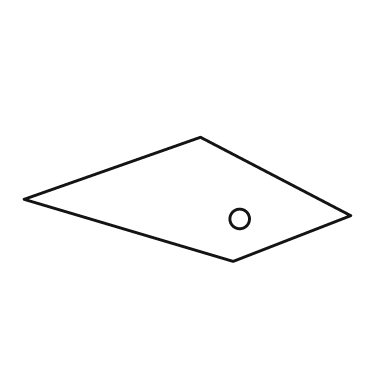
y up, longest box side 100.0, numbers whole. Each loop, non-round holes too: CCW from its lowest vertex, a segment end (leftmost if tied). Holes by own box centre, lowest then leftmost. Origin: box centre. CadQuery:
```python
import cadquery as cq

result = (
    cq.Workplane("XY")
    .moveTo(14.0, -19.0)
    .lineTo(50.0, -5.0)
    .lineTo(4.0, 19.0)
    .lineTo(-50.0, 0.0)
    .close()
    .moveTo(16.0, -6.0)
    .circle(3.0)
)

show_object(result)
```